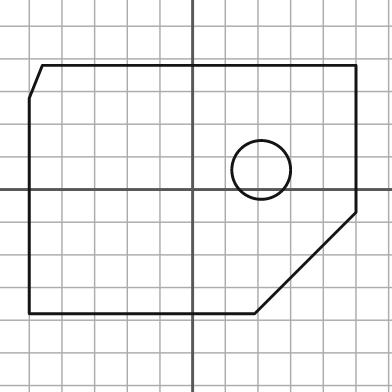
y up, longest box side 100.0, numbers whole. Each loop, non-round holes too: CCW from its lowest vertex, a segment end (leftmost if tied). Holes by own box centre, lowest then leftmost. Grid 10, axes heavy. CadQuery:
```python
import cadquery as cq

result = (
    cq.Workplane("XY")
    .moveTo(-50.0, -38.0)
    .lineTo(19.0, -38.0)
    .lineTo(50.0, -7.0)
    .lineTo(50.0, 38.0)
    .lineTo(-46.0, 38.0)
    .lineTo(-50.0, 28.0)
    .close()
    .moveTo(21.0, 6.0)
    .circle(9.0)
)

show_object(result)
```